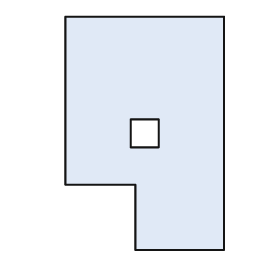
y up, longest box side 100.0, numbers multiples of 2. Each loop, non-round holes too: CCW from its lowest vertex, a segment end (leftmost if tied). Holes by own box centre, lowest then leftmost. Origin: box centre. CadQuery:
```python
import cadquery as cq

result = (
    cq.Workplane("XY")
    .moveTo(-4.0, -50.0)
    .lineTo(34.0, -50.0)
    .lineTo(34.0, 50.0)
    .lineTo(-34.0, 50.0)
    .lineTo(-34.0, -22.0)
    .lineTo(-4.0, -22.0)
    .close()
    .moveTo(-6.0, -6.0)
    .lineTo(6.0, -6.0)
    .lineTo(6.0, 6.0)
    .lineTo(-6.0, 6.0)
    .close()
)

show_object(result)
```